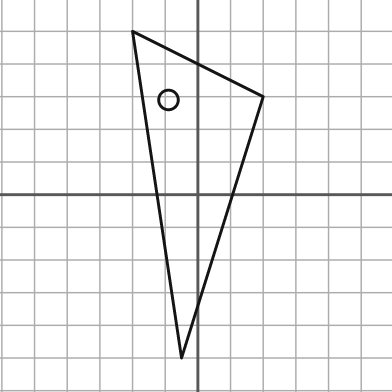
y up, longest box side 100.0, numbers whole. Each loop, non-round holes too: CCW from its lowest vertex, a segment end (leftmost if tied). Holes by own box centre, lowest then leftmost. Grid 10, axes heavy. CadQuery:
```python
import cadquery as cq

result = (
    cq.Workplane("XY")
    .moveTo(-5.0, -50.0)
    .lineTo(20.0, 30.0)
    .lineTo(-20.0, 50.0)
    .close()
    .moveTo(-9.0, 29.0)
    .circle(3.0)
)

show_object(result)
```